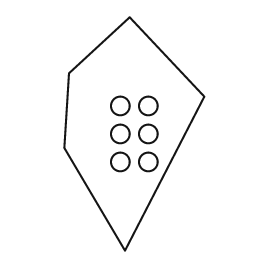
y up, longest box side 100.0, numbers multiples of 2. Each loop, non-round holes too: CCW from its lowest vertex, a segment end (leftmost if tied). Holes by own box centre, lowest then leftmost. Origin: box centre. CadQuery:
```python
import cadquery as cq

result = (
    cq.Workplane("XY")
    .moveTo(-4.0, -50.0)
    .lineTo(30.0, 16.0)
    .lineTo(-2.0, 50.0)
    .lineTo(-28.0, 26.0)
    .lineTo(-30.0, -6.0)
    .close()
    .moveTo(-6.0, -12.0)
    .circle(4.0)
    .moveTo(6.0, -12.0)
    .circle(4.0)
    .moveTo(-6.0, 0.0)
    .circle(4.0)
    .moveTo(6.0, 0.0)
    .circle(4.0)
    .moveTo(-6.0, 12.0)
    .circle(4.0)
    .moveTo(6.0, 12.0)
    .circle(4.0)
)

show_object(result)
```